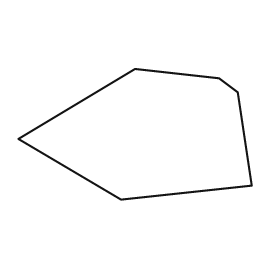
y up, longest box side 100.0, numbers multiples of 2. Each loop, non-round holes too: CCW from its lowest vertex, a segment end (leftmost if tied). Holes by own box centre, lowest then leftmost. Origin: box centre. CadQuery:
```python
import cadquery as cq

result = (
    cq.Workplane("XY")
    .moveTo(-6.0, -28.0)
    .lineTo(50.0, -22.0)
    .lineTo(44.0, 18.0)
    .lineTo(36.0, 24.0)
    .lineTo(0.0, 28.0)
    .lineTo(-50.0, -2.0)
    .close()
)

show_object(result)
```